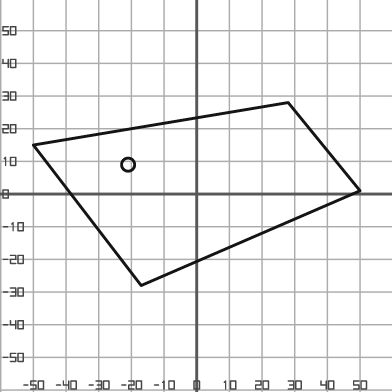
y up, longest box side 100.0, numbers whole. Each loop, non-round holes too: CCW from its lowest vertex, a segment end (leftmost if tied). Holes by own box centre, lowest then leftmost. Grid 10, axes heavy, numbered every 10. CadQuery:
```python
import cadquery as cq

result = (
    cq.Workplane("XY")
    .moveTo(-17.0, -28.0)
    .lineTo(50.0, 1.0)
    .lineTo(28.0, 28.0)
    .lineTo(-50.0, 15.0)
    .close()
    .moveTo(-21.0, 9.0)
    .circle(2.0)
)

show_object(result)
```